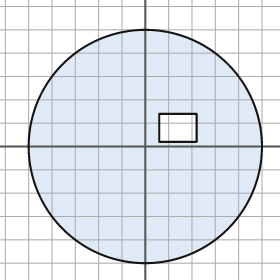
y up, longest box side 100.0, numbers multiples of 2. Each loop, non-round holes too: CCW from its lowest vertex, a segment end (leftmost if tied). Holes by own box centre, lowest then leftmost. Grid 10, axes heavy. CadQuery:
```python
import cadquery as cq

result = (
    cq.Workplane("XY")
    .moveTo(0.0, 0.0)
    .circle(50.0)
    .moveTo(6.0, 2.0)
    .lineTo(22.0, 2.0)
    .lineTo(22.0, 14.0)
    .lineTo(6.0, 14.0)
    .close()
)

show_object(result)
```